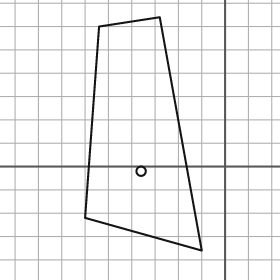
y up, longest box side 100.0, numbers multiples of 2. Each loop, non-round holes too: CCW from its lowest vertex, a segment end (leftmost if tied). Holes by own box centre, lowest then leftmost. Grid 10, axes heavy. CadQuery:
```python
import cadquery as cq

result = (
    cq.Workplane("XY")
    .moveTo(-10.0, -36.0)
    .lineTo(-28.0, 64.0)
    .lineTo(-54.0, 60.0)
    .lineTo(-60.0, -22.0)
    .close()
    .moveTo(-36.0, -2.0)
    .circle(2.0)
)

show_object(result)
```